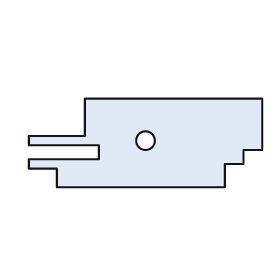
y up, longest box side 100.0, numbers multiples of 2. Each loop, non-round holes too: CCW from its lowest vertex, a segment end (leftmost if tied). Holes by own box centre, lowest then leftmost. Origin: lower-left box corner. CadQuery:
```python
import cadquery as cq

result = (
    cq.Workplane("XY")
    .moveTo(12.0, 0.0)
    .lineTo(84.0, 0.0)
    .lineTo(84.0, 10.0)
    .lineTo(92.0, 10.0)
    .lineTo(92.0, 16.0)
    .lineTo(100.0, 16.0)
    .lineTo(100.0, 38.0)
    .lineTo(24.0, 38.0)
    .lineTo(24.0, 22.0)
    .lineTo(0.0, 22.0)
    .lineTo(0.0, 18.0)
    .lineTo(30.0, 18.0)
    .lineTo(30.0, 12.0)
    .lineTo(0.0, 12.0)
    .lineTo(0.0, 8.0)
    .lineTo(12.0, 8.0)
    .close()
    .moveTo(50.0, 20.0)
    .circle(4.0)
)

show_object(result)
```